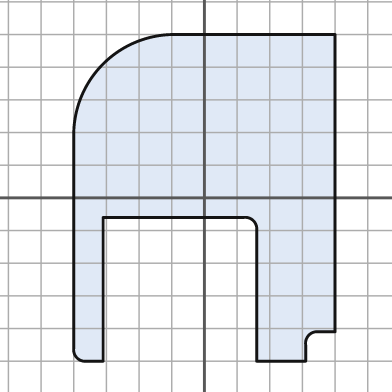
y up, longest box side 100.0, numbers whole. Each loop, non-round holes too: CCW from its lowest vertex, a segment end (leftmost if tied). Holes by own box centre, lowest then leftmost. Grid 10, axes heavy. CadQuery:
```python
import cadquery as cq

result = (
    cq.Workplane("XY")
    .moveTo(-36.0, -50.0)
    .lineTo(-31.0, -50.0)
    .lineTo(-31.0, -6.0)
    .lineTo(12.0, -6.0)
    .threePointArc((15.0, -7.0), (16.0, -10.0))
    .lineTo(16.0, -50.0)
    .lineTo(31.0, -50.0)
    .lineTo(31.0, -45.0)
    .threePointArc((32.0, -42.0), (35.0, -41.0))
    .lineTo(40.0, -41.0)
    .lineTo(40.0, 50.0)
    .lineTo(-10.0, 50.0)
    .threePointArc((-31.0, 41.0), (-40.0, 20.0))
    .lineTo(-40.0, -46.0)
    .threePointArc((-39.0, -49.0), (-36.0, -50.0))
    .close()
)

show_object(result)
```